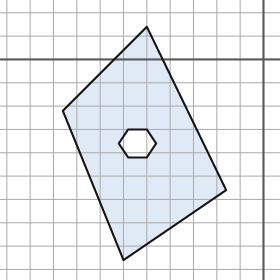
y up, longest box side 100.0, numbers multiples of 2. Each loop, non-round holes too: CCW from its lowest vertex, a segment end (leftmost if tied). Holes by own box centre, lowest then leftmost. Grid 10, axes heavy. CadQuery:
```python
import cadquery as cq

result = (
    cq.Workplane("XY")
    .moveTo(-60.0, -86.0)
    .lineTo(-16.0, -56.0)
    .lineTo(-50.0, 14.0)
    .lineTo(-86.0, -22.0)
    .close()
    .moveTo(-58.0, -42.0)
    .lineTo(-50.0, -42.0)
    .lineTo(-46.0, -36.0)
    .lineTo(-50.0, -30.0)
    .lineTo(-58.0, -30.0)
    .lineTo(-62.0, -36.0)
    .close()
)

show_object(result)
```